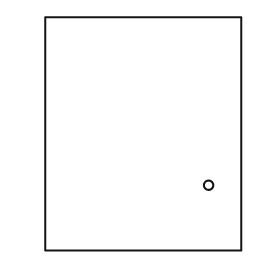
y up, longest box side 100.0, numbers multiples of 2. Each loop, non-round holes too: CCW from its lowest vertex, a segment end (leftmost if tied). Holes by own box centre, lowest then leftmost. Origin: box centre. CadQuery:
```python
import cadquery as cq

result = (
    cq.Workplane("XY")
    .moveTo(-42.0, -50.0)
    .lineTo(42.0, -50.0)
    .lineTo(42.0, 50.0)
    .lineTo(-42.0, 50.0)
    .close()
    .moveTo(28.0, -22.0)
    .circle(2.0)
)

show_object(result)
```